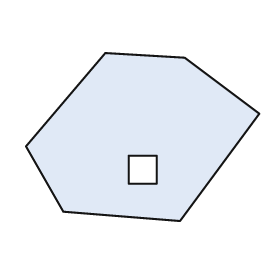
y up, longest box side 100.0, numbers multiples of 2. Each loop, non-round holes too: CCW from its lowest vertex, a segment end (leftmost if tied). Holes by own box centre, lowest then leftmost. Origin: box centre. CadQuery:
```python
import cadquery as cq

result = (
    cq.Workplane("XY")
    .moveTo(16.0, -36.0)
    .lineTo(50.0, 10.0)
    .lineTo(18.0, 34.0)
    .lineTo(-16.0, 36.0)
    .lineTo(-50.0, -4.0)
    .lineTo(-34.0, -32.0)
    .close()
    .moveTo(-6.0, -20.0)
    .lineTo(6.0, -20.0)
    .lineTo(6.0, -8.0)
    .lineTo(-6.0, -8.0)
    .close()
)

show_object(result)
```